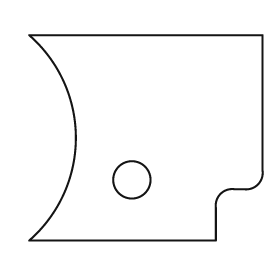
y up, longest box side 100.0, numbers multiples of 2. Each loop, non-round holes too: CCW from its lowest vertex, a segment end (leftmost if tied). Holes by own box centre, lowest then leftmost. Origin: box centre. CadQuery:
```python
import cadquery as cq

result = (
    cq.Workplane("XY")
    .moveTo(-50.0, -44.0)
    .lineTo(30.0, -44.0)
    .lineTo(30.0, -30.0)
    .threePointArc((32.0, -24.0), (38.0, -22.0))
    .lineTo(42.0, -22.0)
    .threePointArc((48.0, -20.0), (50.0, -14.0))
    .lineTo(50.0, 44.0)
    .lineTo(-50.0, 44.0)
    .threePointArc((-30.0, 0.0), (-50.0, -44.0))
    .close()
    .moveTo(-6.0, -18.0)
    .circle(8.0)
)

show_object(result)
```